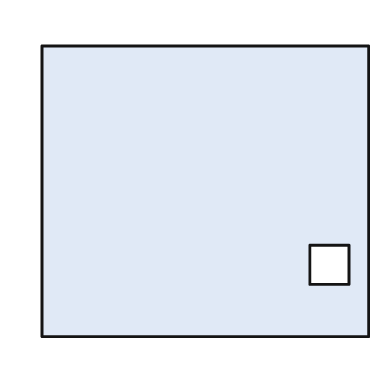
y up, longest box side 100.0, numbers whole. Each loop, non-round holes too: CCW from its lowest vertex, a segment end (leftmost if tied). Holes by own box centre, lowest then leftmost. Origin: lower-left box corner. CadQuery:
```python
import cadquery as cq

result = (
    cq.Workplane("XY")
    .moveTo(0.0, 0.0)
    .lineTo(100.0, 0.0)
    .lineTo(100.0, 89.0)
    .lineTo(0.0, 89.0)
    .close()
    .moveTo(82.0, 16.0)
    .lineTo(94.0, 16.0)
    .lineTo(94.0, 28.0)
    .lineTo(82.0, 28.0)
    .close()
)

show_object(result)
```